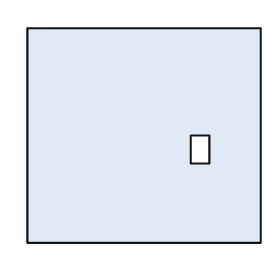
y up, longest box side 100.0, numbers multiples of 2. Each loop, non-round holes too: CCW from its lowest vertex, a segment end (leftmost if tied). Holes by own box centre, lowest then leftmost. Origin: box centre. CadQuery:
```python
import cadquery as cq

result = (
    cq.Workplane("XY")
    .moveTo(-50.0, -46.0)
    .lineTo(50.0, -46.0)
    .lineTo(50.0, 46.0)
    .lineTo(-50.0, 46.0)
    .close()
    .moveTo(20.0, -12.0)
    .lineTo(28.0, -12.0)
    .lineTo(28.0, 0.0)
    .lineTo(20.0, 0.0)
    .close()
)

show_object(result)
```